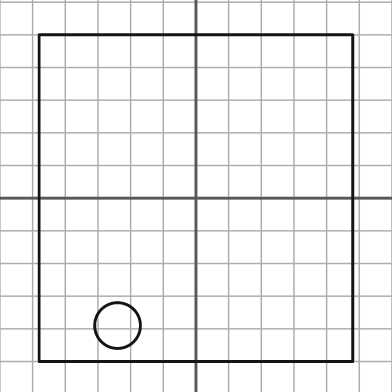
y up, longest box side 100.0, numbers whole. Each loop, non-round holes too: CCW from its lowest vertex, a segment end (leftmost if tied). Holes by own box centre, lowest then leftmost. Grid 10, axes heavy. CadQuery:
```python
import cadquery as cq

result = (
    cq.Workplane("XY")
    .moveTo(-48.0, -50.0)
    .lineTo(48.0, -50.0)
    .lineTo(48.0, 50.0)
    .lineTo(-48.0, 50.0)
    .close()
    .moveTo(-24.0, -39.0)
    .circle(7.0)
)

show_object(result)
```